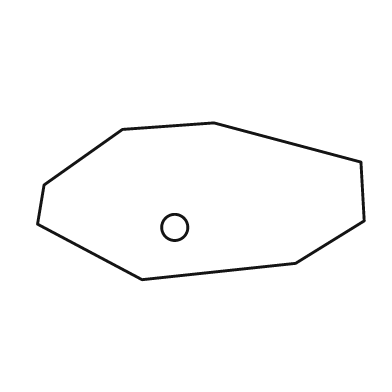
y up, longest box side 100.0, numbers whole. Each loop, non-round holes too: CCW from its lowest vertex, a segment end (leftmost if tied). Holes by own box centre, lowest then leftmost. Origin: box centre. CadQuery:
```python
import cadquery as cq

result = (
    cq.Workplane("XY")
    .moveTo(-18.0, -24.0)
    .lineTo(29.0, -19.0)
    .lineTo(50.0, -6.0)
    .lineTo(49.0, 12.0)
    .lineTo(4.0, 24.0)
    .lineTo(-24.0, 22.0)
    .lineTo(-48.0, 5.0)
    .lineTo(-50.0, -7.0)
    .close()
    .moveTo(-8.0, -8.0)
    .circle(4.0)
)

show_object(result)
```